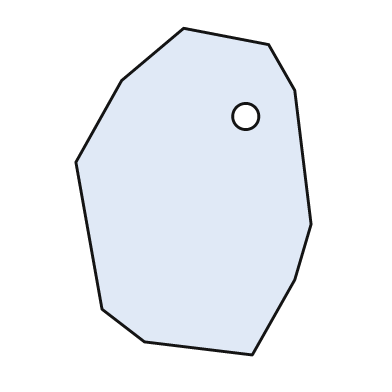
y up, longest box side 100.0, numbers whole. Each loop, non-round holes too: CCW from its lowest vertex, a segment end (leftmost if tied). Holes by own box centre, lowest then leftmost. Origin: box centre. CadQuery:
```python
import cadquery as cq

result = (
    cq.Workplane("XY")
    .moveTo(18.0, -50.0)
    .lineTo(31.0, -27.0)
    .lineTo(36.0, -10.0)
    .lineTo(31.0, 31.0)
    .lineTo(23.0, 45.0)
    .lineTo(-3.0, 50.0)
    .lineTo(-22.0, 34.0)
    .lineTo(-36.0, 9.0)
    .lineTo(-28.0, -36.0)
    .lineTo(-15.0, -46.0)
    .close()
    .moveTo(16.0, 23.0)
    .circle(4.0)
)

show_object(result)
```